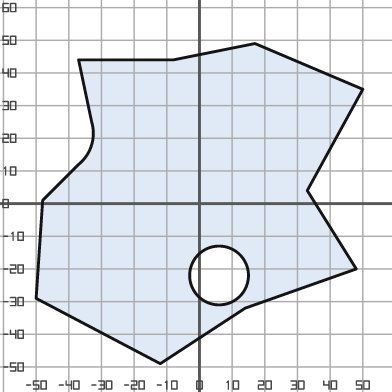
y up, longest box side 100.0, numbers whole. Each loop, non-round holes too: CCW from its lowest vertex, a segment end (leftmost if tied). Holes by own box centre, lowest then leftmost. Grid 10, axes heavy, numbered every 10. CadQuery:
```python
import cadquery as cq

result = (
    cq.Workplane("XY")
    .moveTo(-12.0, -49.0)
    .lineTo(14.0, -32.0)
    .lineTo(48.0, -20.0)
    .lineTo(33.0, 4.0)
    .lineTo(50.0, 35.0)
    .lineTo(17.0, 49.0)
    .lineTo(-8.0, 44.0)
    .lineTo(-37.0, 44.0)
    .lineTo(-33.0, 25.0)
    .threePointArc((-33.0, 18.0), (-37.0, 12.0))
    .lineTo(-48.0, 1.0)
    .lineTo(-50.0, -29.0)
    .close()
    .moveTo(6.0, -22.0)
    .circle(9.0)
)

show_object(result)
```